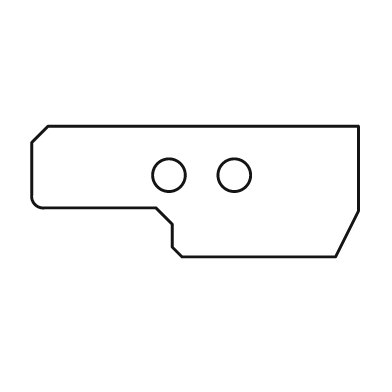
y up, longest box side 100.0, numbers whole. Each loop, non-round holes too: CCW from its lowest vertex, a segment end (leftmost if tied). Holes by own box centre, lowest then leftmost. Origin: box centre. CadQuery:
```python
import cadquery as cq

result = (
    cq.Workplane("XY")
    .moveTo(-4.0, -20.0)
    .lineTo(43.0, -20.0)
    .lineTo(50.0, -6.0)
    .lineTo(50.0, 20.0)
    .lineTo(-45.0, 20.0)
    .lineTo(-50.0, 15.0)
    .lineTo(-50.0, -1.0)
    .threePointArc((-49.0, -4.0), (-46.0, -5.0))
    .lineTo(-12.0, -5.0)
    .lineTo(-7.0, -10.0)
    .lineTo(-7.0, -17.0)
    .close()
    .moveTo(-8.0, 5.0)
    .circle(5.0)
    .moveTo(12.0, 5.0)
    .circle(5.0)
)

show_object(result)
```